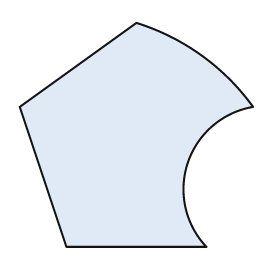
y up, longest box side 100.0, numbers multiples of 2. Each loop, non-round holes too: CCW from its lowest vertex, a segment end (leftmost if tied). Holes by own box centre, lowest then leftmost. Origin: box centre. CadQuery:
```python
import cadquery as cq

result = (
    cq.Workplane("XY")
    .moveTo(-30.0, -48.0)
    .lineTo(30.0, -48.0)
    .threePointArc((22.0, -12.0), (50.0, 12.0))
    .threePointArc((28.0, 34.0), (0.0, 48.0))
    .lineTo(-50.0, 12.0)
    .close()
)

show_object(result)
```